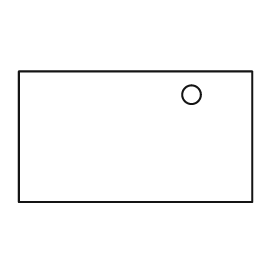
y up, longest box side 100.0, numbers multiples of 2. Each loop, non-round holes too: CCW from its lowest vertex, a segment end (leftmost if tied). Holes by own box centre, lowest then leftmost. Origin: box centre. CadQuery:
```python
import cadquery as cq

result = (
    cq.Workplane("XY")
    .moveTo(-50.0, -28.0)
    .lineTo(50.0, -28.0)
    .lineTo(50.0, 28.0)
    .lineTo(-50.0, 28.0)
    .close()
    .moveTo(24.0, 18.0)
    .circle(4.0)
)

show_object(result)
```